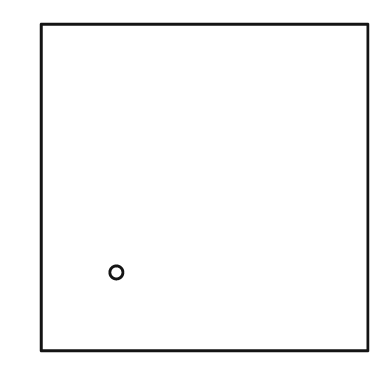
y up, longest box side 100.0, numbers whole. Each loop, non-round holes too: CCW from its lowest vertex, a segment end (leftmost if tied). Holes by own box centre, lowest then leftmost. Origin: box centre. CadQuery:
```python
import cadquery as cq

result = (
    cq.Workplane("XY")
    .moveTo(-50.0, -50.0)
    .lineTo(50.0, -50.0)
    .lineTo(50.0, 50.0)
    .lineTo(-50.0, 50.0)
    .close()
    .moveTo(-27.0, -26.0)
    .circle(2.0)
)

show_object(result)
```